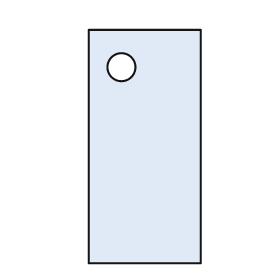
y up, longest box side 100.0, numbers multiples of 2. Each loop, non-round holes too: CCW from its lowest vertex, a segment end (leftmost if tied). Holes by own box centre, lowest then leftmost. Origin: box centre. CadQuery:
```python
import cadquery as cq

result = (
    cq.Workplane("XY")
    .moveTo(-24.0, -50.0)
    .lineTo(24.0, -50.0)
    .lineTo(24.0, 50.0)
    .lineTo(-24.0, 50.0)
    .close()
    .moveTo(-10.0, 34.0)
    .circle(6.0)
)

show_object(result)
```